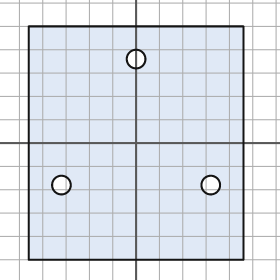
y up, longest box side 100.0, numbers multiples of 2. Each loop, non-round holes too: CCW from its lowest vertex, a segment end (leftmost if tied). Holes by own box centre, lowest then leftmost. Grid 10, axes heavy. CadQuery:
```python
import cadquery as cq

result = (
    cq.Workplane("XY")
    .moveTo(-46.0, -50.0)
    .lineTo(46.0, -50.0)
    .lineTo(46.0, 50.0)
    .lineTo(-46.0, 50.0)
    .close()
    .moveTo(-32.0, -18.0)
    .circle(4.0)
    .moveTo(32.0, -18.0)
    .circle(4.0)
    .moveTo(0.0, 36.0)
    .circle(4.0)
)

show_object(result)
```